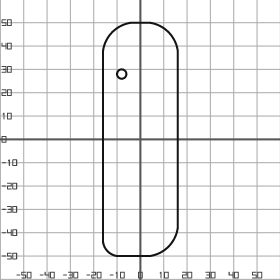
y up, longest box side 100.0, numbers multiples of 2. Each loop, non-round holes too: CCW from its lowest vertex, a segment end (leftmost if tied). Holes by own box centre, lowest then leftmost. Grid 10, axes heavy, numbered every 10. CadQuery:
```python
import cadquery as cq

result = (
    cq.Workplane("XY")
    .moveTo(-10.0, -50.0)
    .lineTo(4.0, -50.0)
    .threePointArc((12.0, -46.0), (16.0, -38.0))
    .lineTo(16.0, 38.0)
    .threePointArc((12.0, 46.0), (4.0, 50.0))
    .lineTo(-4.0, 50.0)
    .threePointArc((-12.0, 46.0), (-16.0, 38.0))
    .lineTo(-16.0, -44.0)
    .threePointArc((-14.0, -48.0), (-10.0, -50.0))
    .close()
    .moveTo(-8.0, 28.0)
    .circle(2.0)
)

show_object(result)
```